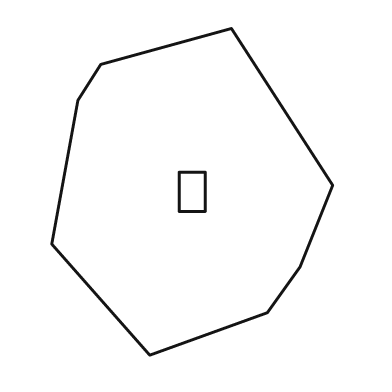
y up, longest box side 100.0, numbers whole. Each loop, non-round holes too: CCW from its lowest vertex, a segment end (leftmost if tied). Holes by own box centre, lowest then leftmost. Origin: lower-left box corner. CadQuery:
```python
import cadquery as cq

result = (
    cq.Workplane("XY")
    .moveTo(30.0, 0.0)
    .lineTo(66.0, 13.0)
    .lineTo(76.0, 27.0)
    .lineTo(86.0, 52.0)
    .lineTo(55.0, 100.0)
    .lineTo(15.0, 89.0)
    .lineTo(8.0, 78.0)
    .lineTo(0.0, 34.0)
    .close()
    .moveTo(39.0, 44.0)
    .lineTo(47.0, 44.0)
    .lineTo(47.0, 56.0)
    .lineTo(39.0, 56.0)
    .close()
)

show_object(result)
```